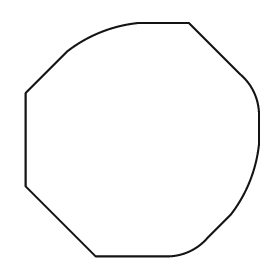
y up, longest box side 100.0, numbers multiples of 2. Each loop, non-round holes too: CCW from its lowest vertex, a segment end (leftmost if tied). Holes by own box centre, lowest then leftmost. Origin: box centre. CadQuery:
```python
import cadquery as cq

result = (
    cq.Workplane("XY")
    .moveTo(-20.0, -50.0)
    .lineTo(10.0, -50.0)
    .threePointArc((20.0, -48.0), (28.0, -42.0))
    .lineTo(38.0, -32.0)
    .threePointArc((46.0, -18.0), (50.0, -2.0))
    .lineTo(50.0, 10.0)
    .threePointArc((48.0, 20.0), (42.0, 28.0))
    .lineTo(20.0, 50.0)
    .lineTo(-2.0, 50.0)
    .threePointArc((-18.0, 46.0), (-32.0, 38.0))
    .lineTo(-50.0, 20.0)
    .lineTo(-50.0, -20.0)
    .close()
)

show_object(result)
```